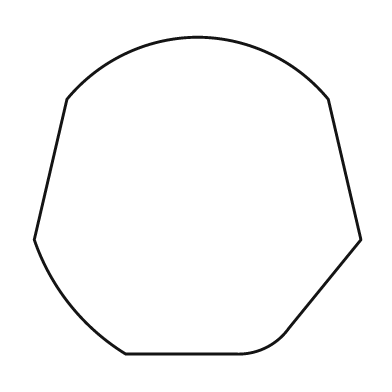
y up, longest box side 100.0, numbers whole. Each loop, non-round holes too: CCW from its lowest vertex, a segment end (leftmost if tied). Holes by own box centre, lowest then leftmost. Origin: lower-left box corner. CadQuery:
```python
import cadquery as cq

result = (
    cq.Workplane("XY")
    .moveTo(28.0, 0.0)
    .lineTo(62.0, 0.0)
    .threePointArc((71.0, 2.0), (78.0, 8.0))
    .lineTo(100.0, 35.0)
    .lineTo(90.0, 78.0)
    .threePointArc((72.0, 92.0), (50.0, 97.0))
    .threePointArc((28.0, 92.0), (10.0, 78.0))
    .lineTo(0.0, 35.0)
    .threePointArc((11.0, 15.0), (28.0, 0.0))
    .close()
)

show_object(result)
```